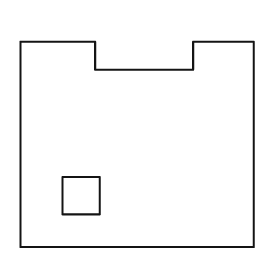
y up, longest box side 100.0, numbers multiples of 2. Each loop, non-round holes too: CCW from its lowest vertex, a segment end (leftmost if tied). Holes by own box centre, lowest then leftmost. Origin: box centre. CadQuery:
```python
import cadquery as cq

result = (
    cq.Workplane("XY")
    .moveTo(-50.0, -44.0)
    .lineTo(50.0, -44.0)
    .lineTo(50.0, 44.0)
    .lineTo(24.0, 44.0)
    .lineTo(24.0, 32.0)
    .lineTo(-18.0, 32.0)
    .lineTo(-18.0, 44.0)
    .lineTo(-50.0, 44.0)
    .close()
    .moveTo(-32.0, -30.0)
    .lineTo(-16.0, -30.0)
    .lineTo(-16.0, -14.0)
    .lineTo(-32.0, -14.0)
    .close()
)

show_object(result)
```